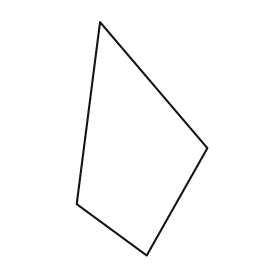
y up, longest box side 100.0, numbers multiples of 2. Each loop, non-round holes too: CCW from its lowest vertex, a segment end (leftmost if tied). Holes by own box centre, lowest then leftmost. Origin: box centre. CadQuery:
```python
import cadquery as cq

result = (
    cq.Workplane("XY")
    .moveTo(2.0, -50.0)
    .lineTo(28.0, -4.0)
    .lineTo(-18.0, 50.0)
    .lineTo(-28.0, -28.0)
    .close()
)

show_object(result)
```